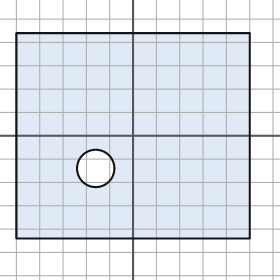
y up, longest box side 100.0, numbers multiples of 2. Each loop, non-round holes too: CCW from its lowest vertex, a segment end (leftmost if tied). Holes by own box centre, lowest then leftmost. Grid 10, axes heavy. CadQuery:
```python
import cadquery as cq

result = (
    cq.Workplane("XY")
    .moveTo(-50.0, -44.0)
    .lineTo(50.0, -44.0)
    .lineTo(50.0, 44.0)
    .lineTo(-50.0, 44.0)
    .close()
    .moveTo(-16.0, -14.0)
    .circle(8.0)
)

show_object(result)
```